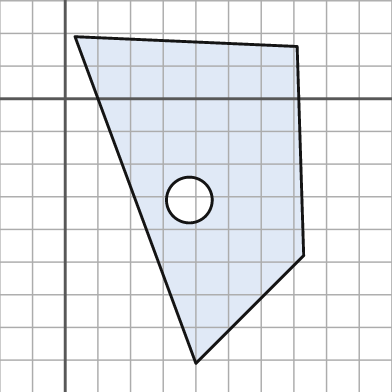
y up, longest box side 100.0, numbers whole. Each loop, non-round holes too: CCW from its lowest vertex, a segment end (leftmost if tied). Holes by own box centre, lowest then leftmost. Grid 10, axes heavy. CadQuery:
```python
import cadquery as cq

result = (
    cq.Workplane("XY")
    .moveTo(40.0, -81.0)
    .lineTo(73.0, -48.0)
    .lineTo(71.0, 16.0)
    .lineTo(3.0, 19.0)
    .close()
    .moveTo(38.0, -31.0)
    .circle(7.0)
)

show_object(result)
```